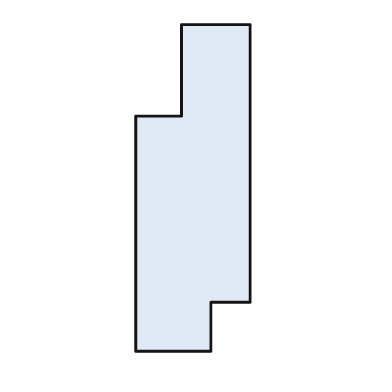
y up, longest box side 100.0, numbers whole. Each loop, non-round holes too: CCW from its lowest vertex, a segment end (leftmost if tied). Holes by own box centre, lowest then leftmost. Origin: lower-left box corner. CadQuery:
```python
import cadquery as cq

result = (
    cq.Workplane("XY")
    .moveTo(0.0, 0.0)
    .lineTo(23.0, 0.0)
    .lineTo(23.0, 15.0)
    .lineTo(35.0, 15.0)
    .lineTo(35.0, 100.0)
    .lineTo(14.0, 100.0)
    .lineTo(14.0, 72.0)
    .lineTo(0.0, 72.0)
    .close()
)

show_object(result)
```